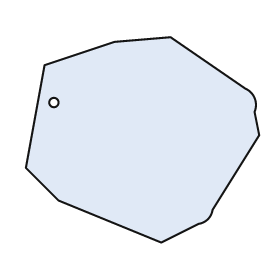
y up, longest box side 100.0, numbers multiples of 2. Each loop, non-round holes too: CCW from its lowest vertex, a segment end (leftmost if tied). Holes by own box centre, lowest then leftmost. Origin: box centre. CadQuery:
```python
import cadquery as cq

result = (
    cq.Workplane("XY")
    .moveTo(8.0, -44.0)
    .lineTo(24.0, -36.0)
    .threePointArc((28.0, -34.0), (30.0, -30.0))
    .lineTo(50.0, 2.0)
    .lineTo(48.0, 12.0)
    .threePointArc((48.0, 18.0), (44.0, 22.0))
    .lineTo(12.0, 44.0)
    .lineTo(-12.0, 42.0)
    .lineTo(-42.0, 32.0)
    .lineTo(-50.0, -12.0)
    .lineTo(-36.0, -26.0)
    .close()
    .moveTo(-38.0, 16.0)
    .circle(2.0)
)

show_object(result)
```